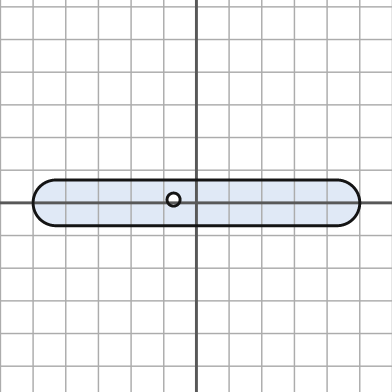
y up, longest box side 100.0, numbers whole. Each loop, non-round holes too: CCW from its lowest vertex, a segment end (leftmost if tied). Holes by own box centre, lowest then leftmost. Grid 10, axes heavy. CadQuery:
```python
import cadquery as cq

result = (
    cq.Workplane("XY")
    .moveTo(-43.0, -7.0)
    .lineTo(43.0, -7.0)
    .threePointArc((50.0, 0.0), (43.0, 7.0))
    .lineTo(-43.0, 7.0)
    .threePointArc((-50.0, 0.0), (-43.0, -7.0))
    .close()
    .moveTo(-7.0, 1.0)
    .circle(2.0)
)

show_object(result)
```